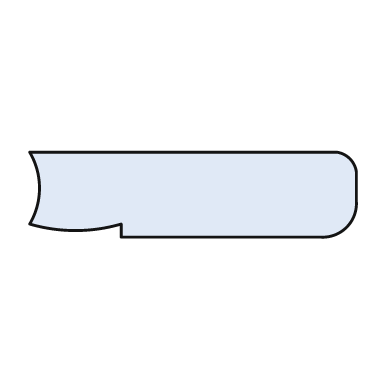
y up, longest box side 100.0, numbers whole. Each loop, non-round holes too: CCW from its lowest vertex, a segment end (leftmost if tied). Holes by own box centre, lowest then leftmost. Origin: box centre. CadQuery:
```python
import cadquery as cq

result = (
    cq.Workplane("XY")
    .moveTo(-22.0, -13.0)
    .lineTo(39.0, -13.0)
    .threePointArc((47.0, -10.0), (50.0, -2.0))
    .lineTo(50.0, 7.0)
    .threePointArc((48.0, 11.0), (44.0, 13.0))
    .lineTo(-50.0, 13.0)
    .threePointArc((-47.0, 2.0), (-50.0, -9.0))
    .threePointArc((-36.0, -11.0), (-22.0, -9.0))
    .close()
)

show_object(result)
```